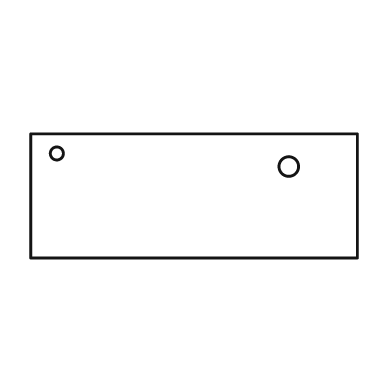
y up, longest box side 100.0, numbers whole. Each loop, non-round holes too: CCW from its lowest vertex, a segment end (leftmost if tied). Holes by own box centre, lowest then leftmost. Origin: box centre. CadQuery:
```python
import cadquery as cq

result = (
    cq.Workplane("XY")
    .moveTo(-50.0, -19.0)
    .lineTo(50.0, -19.0)
    .lineTo(50.0, 19.0)
    .lineTo(-50.0, 19.0)
    .close()
    .moveTo(29.0, 9.0)
    .circle(3.0)
    .moveTo(-42.0, 13.0)
    .circle(2.0)
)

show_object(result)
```